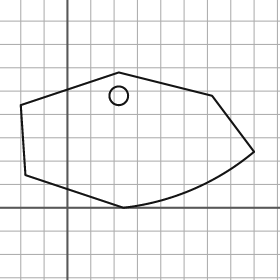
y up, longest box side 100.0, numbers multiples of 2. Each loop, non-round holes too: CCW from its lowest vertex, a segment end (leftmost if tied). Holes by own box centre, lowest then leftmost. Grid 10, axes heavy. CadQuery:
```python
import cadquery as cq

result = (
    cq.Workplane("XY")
    .moveTo(24.0, 0.0)
    .threePointArc((54.0, 8.0), (80.0, 24.0))
    .lineTo(62.0, 48.0)
    .lineTo(22.0, 58.0)
    .lineTo(-20.0, 44.0)
    .lineTo(-18.0, 14.0)
    .close()
    .moveTo(22.0, 48.0)
    .circle(4.0)
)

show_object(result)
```